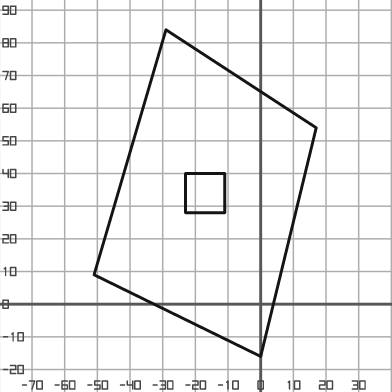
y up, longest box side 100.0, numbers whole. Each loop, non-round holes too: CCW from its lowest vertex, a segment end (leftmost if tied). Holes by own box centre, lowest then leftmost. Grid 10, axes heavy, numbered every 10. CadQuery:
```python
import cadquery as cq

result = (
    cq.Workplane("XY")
    .moveTo(0.0, -16.0)
    .lineTo(17.0, 54.0)
    .lineTo(-29.0, 84.0)
    .lineTo(-51.0, 9.0)
    .close()
    .moveTo(-23.0, 28.0)
    .lineTo(-11.0, 28.0)
    .lineTo(-11.0, 40.0)
    .lineTo(-23.0, 40.0)
    .close()
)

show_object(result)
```